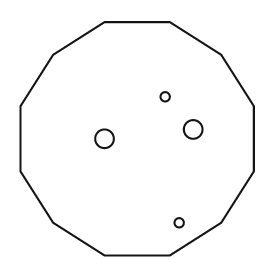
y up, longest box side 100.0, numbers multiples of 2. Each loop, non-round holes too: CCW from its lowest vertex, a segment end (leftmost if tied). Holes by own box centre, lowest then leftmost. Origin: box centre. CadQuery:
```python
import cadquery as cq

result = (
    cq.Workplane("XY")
    .moveTo(-14.0, -50.0)
    .lineTo(14.0, -50.0)
    .lineTo(36.0, -36.0)
    .lineTo(50.0, -14.0)
    .lineTo(50.0, 14.0)
    .lineTo(36.0, 36.0)
    .lineTo(14.0, 50.0)
    .lineTo(-14.0, 50.0)
    .lineTo(-36.0, 36.0)
    .lineTo(-50.0, 14.0)
    .lineTo(-50.0, -14.0)
    .lineTo(-36.0, -36.0)
    .close()
    .moveTo(18.0, -36.0)
    .circle(2.0)
    .moveTo(-14.0, 0.0)
    .circle(4.0)
    .moveTo(24.0, 4.0)
    .circle(4.0)
    .moveTo(12.0, 18.0)
    .circle(2.0)
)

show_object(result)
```